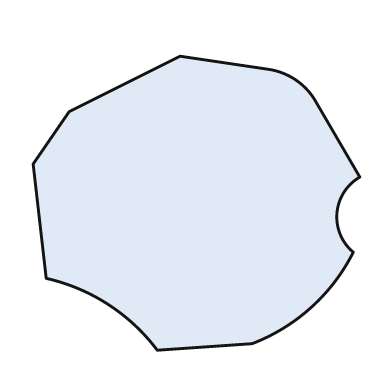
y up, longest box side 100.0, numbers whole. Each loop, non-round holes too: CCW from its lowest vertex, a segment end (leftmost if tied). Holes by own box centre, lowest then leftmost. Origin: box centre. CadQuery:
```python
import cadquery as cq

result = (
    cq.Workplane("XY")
    .moveTo(-12.0, -45.0)
    .lineTo(17.0, -43.0)
    .threePointArc((35.0, -32.0), (48.0, -15.0))
    .threePointArc((43.0, -3.0), (50.0, 8.0))
    .lineTo(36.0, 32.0)
    .threePointArc((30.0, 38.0), (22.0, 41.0))
    .lineTo(-5.0, 45.0)
    .lineTo(-39.0, 28.0)
    .lineTo(-50.0, 12.0)
    .lineTo(-46.0, -23.0)
    .threePointArc((-27.0, -31.0), (-12.0, -45.0))
    .close()
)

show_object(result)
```